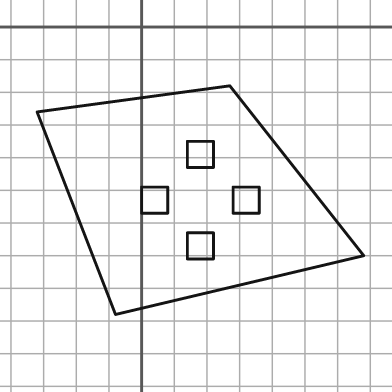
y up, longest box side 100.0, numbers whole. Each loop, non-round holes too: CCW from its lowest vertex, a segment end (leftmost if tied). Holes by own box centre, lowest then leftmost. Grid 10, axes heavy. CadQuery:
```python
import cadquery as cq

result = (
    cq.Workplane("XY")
    .moveTo(-8.0, -88.0)
    .lineTo(68.0, -70.0)
    .lineTo(27.0, -18.0)
    .lineTo(-32.0, -26.0)
    .close()
    .moveTo(14.0, -71.0)
    .lineTo(22.0, -71.0)
    .lineTo(22.0, -63.0)
    .lineTo(14.0, -63.0)
    .close()
    .moveTo(0.0, -57.0)
    .lineTo(8.0, -57.0)
    .lineTo(8.0, -49.0)
    .lineTo(0.0, -49.0)
    .close()
    .moveTo(28.0, -57.0)
    .lineTo(36.0, -57.0)
    .lineTo(36.0, -49.0)
    .lineTo(28.0, -49.0)
    .close()
    .moveTo(14.0, -43.0)
    .lineTo(22.0, -43.0)
    .lineTo(22.0, -35.0)
    .lineTo(14.0, -35.0)
    .close()
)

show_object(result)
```